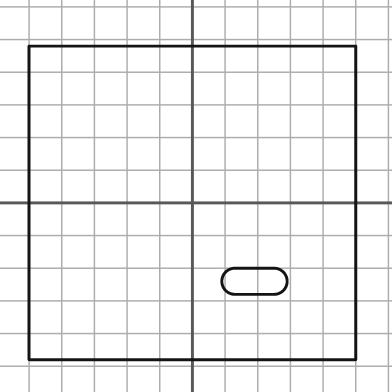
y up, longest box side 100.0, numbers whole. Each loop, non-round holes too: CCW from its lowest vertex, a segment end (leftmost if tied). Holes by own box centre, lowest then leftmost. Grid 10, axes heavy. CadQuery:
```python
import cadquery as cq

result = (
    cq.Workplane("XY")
    .moveTo(-50.0, -48.0)
    .lineTo(50.0, -48.0)
    .lineTo(50.0, 48.0)
    .lineTo(-50.0, 48.0)
    .close()
    .moveTo(13.0, -28.0)
    .lineTo(25.0, -28.0)
    .threePointArc((29.0, -24.0), (25.0, -20.0))
    .lineTo(13.0, -20.0)
    .threePointArc((9.0, -24.0), (13.0, -28.0))
    .close()
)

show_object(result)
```